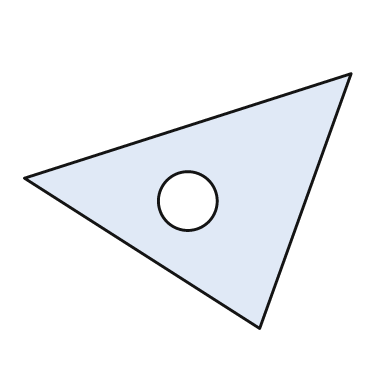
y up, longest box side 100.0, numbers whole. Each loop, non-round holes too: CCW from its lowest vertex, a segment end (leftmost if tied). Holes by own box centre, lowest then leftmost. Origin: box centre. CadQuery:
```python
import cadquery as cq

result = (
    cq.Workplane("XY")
    .moveTo(22.0, -39.0)
    .lineTo(50.0, 39.0)
    .lineTo(-50.0, 7.0)
    .close()
    .moveTo(0.0, 0.0)
    .circle(9.0)
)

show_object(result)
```